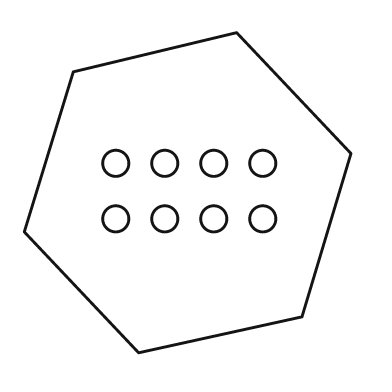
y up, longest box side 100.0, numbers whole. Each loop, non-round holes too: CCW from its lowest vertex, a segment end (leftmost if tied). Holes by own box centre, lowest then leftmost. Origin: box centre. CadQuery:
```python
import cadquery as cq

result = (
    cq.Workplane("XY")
    .moveTo(-15.0, -49.0)
    .lineTo(35.0, -38.0)
    .lineTo(50.0, 12.0)
    .lineTo(15.0, 49.0)
    .lineTo(-35.0, 37.0)
    .lineTo(-50.0, -12.0)
    .close()
    .moveTo(-22.0, -8.0)
    .circle(4.0)
    .moveTo(-7.0, -8.0)
    .circle(4.0)
    .moveTo(8.0, -8.0)
    .circle(4.0)
    .moveTo(23.0, -8.0)
    .circle(4.0)
    .moveTo(-22.0, 9.0)
    .circle(4.0)
    .moveTo(-7.0, 9.0)
    .circle(4.0)
    .moveTo(8.0, 9.0)
    .circle(4.0)
    .moveTo(23.0, 9.0)
    .circle(4.0)
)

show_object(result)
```